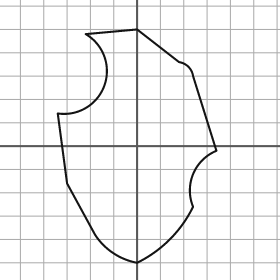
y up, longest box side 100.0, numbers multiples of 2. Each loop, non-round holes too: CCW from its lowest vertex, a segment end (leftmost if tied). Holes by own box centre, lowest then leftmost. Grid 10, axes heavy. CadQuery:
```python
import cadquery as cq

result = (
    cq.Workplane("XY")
    .moveTo(0.0, -50.0)
    .threePointArc((14.0, -40.0), (24.0, -26.0))
    .threePointArc((24.0, -12.0), (34.0, -2.0))
    .lineTo(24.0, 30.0)
    .threePointArc((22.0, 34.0), (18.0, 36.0))
    .lineTo(0.0, 50.0)
    .lineTo(-22.0, 48.0)
    .threePointArc((-14.0, 26.0), (-34.0, 14.0))
    .lineTo(-30.0, -16.0)
    .lineTo(-18.0, -38.0)
    .threePointArc((-10.0, -46.0), (0.0, -50.0))
    .close()
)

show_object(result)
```